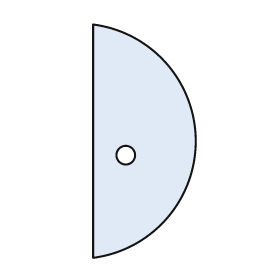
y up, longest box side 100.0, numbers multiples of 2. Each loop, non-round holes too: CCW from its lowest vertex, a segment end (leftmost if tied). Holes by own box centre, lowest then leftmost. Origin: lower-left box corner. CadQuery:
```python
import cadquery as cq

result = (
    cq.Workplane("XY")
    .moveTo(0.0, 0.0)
    .threePointArc((44.0, 50.0), (0.0, 100.0))
    .close()
    .moveTo(14.0, 44.0)
    .circle(4.0)
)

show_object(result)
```